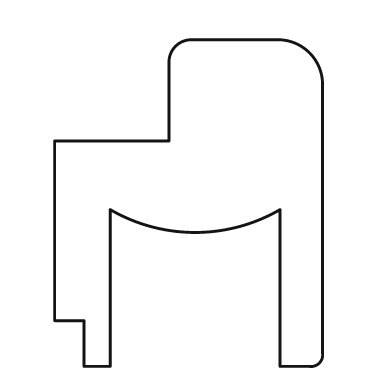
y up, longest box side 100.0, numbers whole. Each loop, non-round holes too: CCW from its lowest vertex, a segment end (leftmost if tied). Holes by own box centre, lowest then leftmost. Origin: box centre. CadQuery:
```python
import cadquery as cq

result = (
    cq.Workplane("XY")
    .moveTo(-32.0, -50.0)
    .lineTo(-24.0, -50.0)
    .lineTo(-24.0, -2.0)
    .threePointArc((2.0, -9.0), (28.0, -2.0))
    .lineTo(28.0, -50.0)
    .lineTo(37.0, -50.0)
    .threePointArc((40.0, -49.0), (41.0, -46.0))
    .lineTo(41.0, 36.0)
    .threePointArc((37.0, 46.0), (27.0, 50.0))
    .lineTo(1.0, 50.0)
    .threePointArc((-4.0, 48.0), (-6.0, 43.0))
    .lineTo(-6.0, 19.0)
    .lineTo(-41.0, 19.0)
    .lineTo(-41.0, -36.0)
    .lineTo(-32.0, -36.0)
    .close()
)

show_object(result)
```